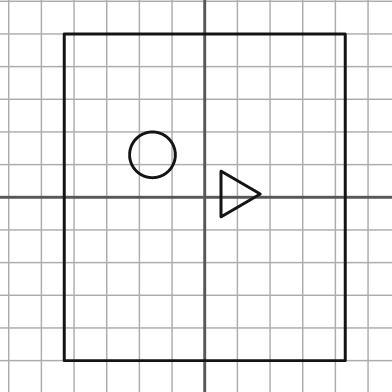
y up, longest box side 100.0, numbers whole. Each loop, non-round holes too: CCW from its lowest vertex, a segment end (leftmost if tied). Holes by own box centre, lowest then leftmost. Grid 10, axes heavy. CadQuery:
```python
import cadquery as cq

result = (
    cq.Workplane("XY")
    .moveTo(-43.0, -50.0)
    .lineTo(43.0, -50.0)
    .lineTo(43.0, 50.0)
    .lineTo(-43.0, 50.0)
    .close()
    .moveTo(5.0, -6.0)
    .lineTo(17.0, 1.0)
    .lineTo(5.0, 8.0)
    .close()
    .moveTo(-16.0, 13.0)
    .circle(7.0)
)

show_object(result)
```